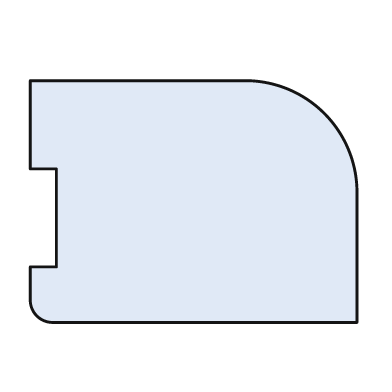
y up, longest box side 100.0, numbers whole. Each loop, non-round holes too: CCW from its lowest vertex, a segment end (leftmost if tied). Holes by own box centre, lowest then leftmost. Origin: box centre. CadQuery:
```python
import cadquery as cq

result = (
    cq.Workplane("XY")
    .moveTo(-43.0, -37.0)
    .lineTo(50.0, -37.0)
    .lineTo(50.0, 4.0)
    .threePointArc((40.0, 27.0), (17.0, 37.0))
    .lineTo(-50.0, 37.0)
    .lineTo(-50.0, 10.0)
    .lineTo(-42.0, 10.0)
    .lineTo(-42.0, -20.0)
    .lineTo(-50.0, -20.0)
    .lineTo(-50.0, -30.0)
    .threePointArc((-48.0, -35.0), (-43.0, -37.0))
    .close()
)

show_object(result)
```